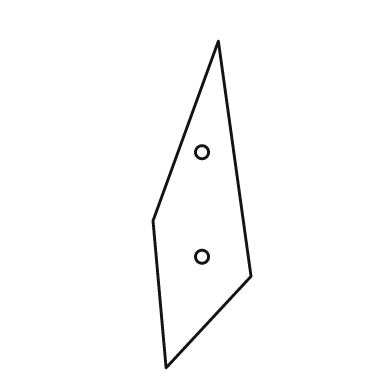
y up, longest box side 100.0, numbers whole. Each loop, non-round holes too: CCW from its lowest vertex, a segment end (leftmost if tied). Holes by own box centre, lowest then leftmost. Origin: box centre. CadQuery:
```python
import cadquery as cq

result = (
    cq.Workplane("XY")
    .moveTo(-11.0, -50.0)
    .lineTo(15.0, -22.0)
    .lineTo(5.0, 50.0)
    .lineTo(-15.0, -5.0)
    .close()
    .moveTo(0.0, -16.0)
    .circle(2.0)
    .moveTo(0.0, 16.0)
    .circle(2.0)
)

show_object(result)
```